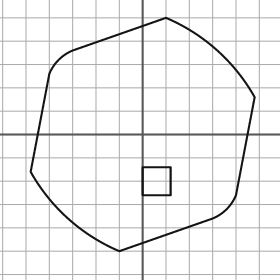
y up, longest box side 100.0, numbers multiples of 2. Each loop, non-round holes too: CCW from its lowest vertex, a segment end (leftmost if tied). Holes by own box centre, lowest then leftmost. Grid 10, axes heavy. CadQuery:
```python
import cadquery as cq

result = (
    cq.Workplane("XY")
    .moveTo(-10.0, -50.0)
    .lineTo(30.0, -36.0)
    .threePointArc((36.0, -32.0), (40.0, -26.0))
    .lineTo(48.0, 16.0)
    .threePointArc((32.0, 36.0), (10.0, 50.0))
    .lineTo(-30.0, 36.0)
    .threePointArc((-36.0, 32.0), (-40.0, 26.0))
    .lineTo(-48.0, -16.0)
    .threePointArc((-32.0, -36.0), (-10.0, -50.0))
    .close()
    .moveTo(0.0, -26.0)
    .lineTo(12.0, -26.0)
    .lineTo(12.0, -14.0)
    .lineTo(0.0, -14.0)
    .close()
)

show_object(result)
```